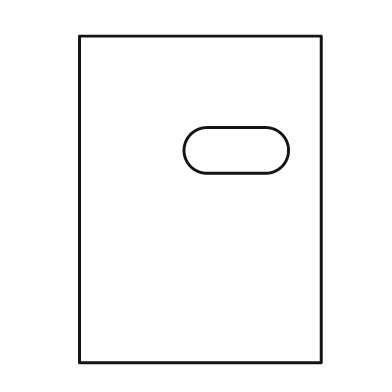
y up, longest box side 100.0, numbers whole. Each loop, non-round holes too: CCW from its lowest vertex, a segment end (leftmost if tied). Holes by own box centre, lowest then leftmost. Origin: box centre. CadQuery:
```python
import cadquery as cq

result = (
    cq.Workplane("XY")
    .moveTo(-37.0, -50.0)
    .lineTo(37.0, -50.0)
    .lineTo(37.0, 50.0)
    .lineTo(-37.0, 50.0)
    .close()
    .moveTo(2.0, 8.0)
    .lineTo(20.0, 8.0)
    .threePointArc((27.0, 15.0), (20.0, 22.0))
    .lineTo(2.0, 22.0)
    .threePointArc((-5.0, 15.0), (2.0, 8.0))
    .close()
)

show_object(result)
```